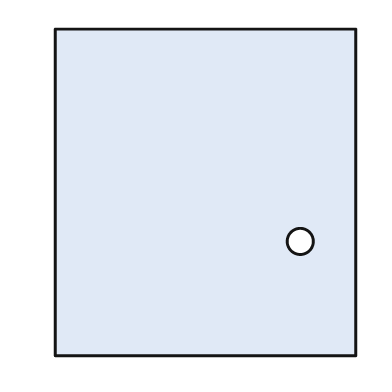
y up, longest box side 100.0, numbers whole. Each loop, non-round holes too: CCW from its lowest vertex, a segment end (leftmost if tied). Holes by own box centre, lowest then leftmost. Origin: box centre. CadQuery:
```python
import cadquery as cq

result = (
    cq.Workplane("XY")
    .moveTo(-46.0, -50.0)
    .lineTo(46.0, -50.0)
    .lineTo(46.0, 50.0)
    .lineTo(-46.0, 50.0)
    .close()
    .moveTo(29.0, -15.0)
    .circle(4.0)
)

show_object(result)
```